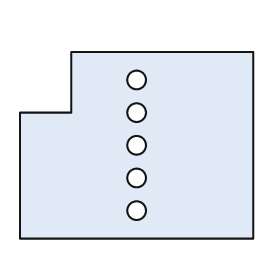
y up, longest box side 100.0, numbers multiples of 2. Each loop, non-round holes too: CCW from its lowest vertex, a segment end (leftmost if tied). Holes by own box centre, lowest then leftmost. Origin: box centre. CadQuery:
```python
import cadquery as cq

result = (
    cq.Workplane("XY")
    .moveTo(-50.0, -40.0)
    .lineTo(50.0, -40.0)
    .lineTo(50.0, 40.0)
    .lineTo(-28.0, 40.0)
    .lineTo(-28.0, 14.0)
    .lineTo(-50.0, 14.0)
    .close()
    .moveTo(0.0, -28.0)
    .circle(4.0)
    .moveTo(0.0, -14.0)
    .circle(4.0)
    .moveTo(0.0, 0.0)
    .circle(4.0)
    .moveTo(0.0, 14.0)
    .circle(4.0)
    .moveTo(0.0, 28.0)
    .circle(4.0)
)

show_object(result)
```